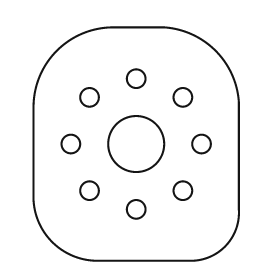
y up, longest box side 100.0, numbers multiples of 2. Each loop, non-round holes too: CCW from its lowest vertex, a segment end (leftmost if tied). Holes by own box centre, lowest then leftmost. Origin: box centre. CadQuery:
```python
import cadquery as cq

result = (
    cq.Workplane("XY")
    .moveTo(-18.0, -50.0)
    .lineTo(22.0, -50.0)
    .threePointArc((38.0, -44.0), (44.0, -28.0))
    .lineTo(44.0, 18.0)
    .threePointArc((34.0, 40.0), (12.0, 50.0))
    .lineTo(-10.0, 50.0)
    .threePointArc((-34.0, 40.0), (-44.0, 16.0))
    .lineTo(-44.0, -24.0)
    .threePointArc((-36.0, -42.0), (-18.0, -50.0))
    .close()
    .moveTo(0.0, -28.0)
    .circle(4.0)
    .moveTo(-20.0, -20.0)
    .circle(4.0)
    .moveTo(20.0, -20.0)
    .circle(4.0)
    .moveTo(-28.0, 0.0)
    .circle(4.0)
    .moveTo(0.0, 0.0)
    .circle(12.0)
    .moveTo(28.0, 0.0)
    .circle(4.0)
    .moveTo(-20.0, 20.0)
    .circle(4.0)
    .moveTo(20.0, 20.0)
    .circle(4.0)
    .moveTo(0.0, 28.0)
    .circle(4.0)
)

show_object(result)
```